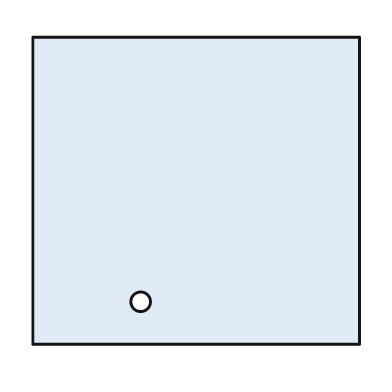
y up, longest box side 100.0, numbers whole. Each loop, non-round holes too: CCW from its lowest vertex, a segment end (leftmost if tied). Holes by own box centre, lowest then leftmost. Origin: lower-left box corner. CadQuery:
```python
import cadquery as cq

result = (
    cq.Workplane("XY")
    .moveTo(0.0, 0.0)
    .lineTo(100.0, 0.0)
    .lineTo(100.0, 94.0)
    .lineTo(0.0, 94.0)
    .close()
    .moveTo(33.0, 13.0)
    .circle(3.0)
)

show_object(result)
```